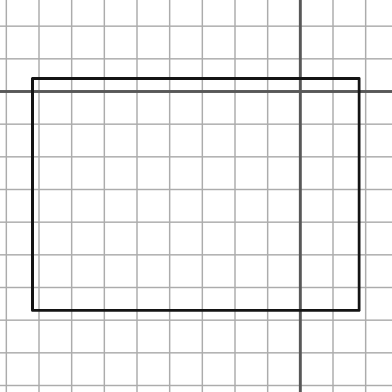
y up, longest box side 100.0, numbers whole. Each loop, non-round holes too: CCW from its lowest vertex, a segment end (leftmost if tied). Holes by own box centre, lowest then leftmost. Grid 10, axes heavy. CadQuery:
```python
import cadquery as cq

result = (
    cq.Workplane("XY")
    .moveTo(-82.0, -67.0)
    .lineTo(18.0, -67.0)
    .lineTo(18.0, 4.0)
    .lineTo(-82.0, 4.0)
    .close()
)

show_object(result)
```